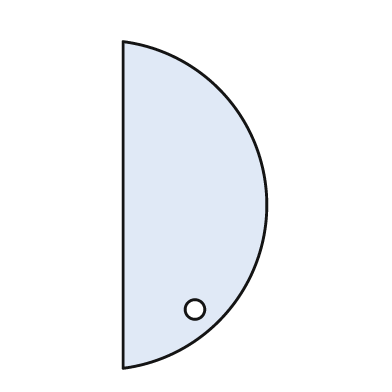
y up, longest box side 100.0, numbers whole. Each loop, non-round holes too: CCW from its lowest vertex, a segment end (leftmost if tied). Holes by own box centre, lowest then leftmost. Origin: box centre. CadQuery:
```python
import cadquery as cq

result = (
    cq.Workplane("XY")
    .moveTo(-22.0, -50.0)
    .threePointArc((22.0, 0.0), (-22.0, 50.0))
    .close()
    .moveTo(0.0, -32.0)
    .circle(3.0)
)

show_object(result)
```